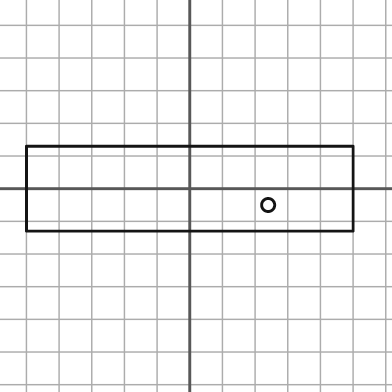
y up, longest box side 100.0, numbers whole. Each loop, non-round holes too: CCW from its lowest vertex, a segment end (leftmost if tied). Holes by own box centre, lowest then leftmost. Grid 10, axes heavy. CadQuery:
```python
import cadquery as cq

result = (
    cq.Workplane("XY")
    .moveTo(-50.0, -13.0)
    .lineTo(50.0, -13.0)
    .lineTo(50.0, 13.0)
    .lineTo(-50.0, 13.0)
    .close()
    .moveTo(24.0, -5.0)
    .circle(2.0)
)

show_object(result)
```